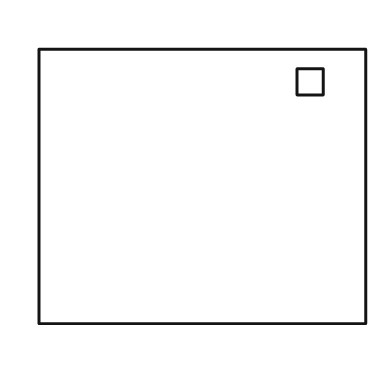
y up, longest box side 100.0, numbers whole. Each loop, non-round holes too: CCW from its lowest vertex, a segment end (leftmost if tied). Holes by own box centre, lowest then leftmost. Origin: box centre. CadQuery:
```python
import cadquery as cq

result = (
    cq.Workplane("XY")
    .moveTo(-50.0, -42.0)
    .lineTo(50.0, -42.0)
    .lineTo(50.0, 42.0)
    .lineTo(-50.0, 42.0)
    .close()
    .moveTo(29.0, 28.0)
    .lineTo(37.0, 28.0)
    .lineTo(37.0, 36.0)
    .lineTo(29.0, 36.0)
    .close()
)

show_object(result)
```